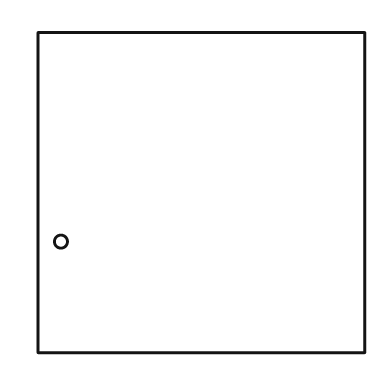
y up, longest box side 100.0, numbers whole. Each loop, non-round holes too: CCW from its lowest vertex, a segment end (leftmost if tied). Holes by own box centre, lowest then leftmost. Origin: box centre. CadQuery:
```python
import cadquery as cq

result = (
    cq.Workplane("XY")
    .moveTo(-50.0, -49.0)
    .lineTo(50.0, -49.0)
    .lineTo(50.0, 49.0)
    .lineTo(-50.0, 49.0)
    .close()
    .moveTo(-43.0, -15.0)
    .circle(2.0)
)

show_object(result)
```